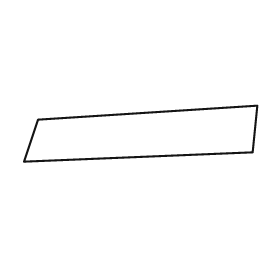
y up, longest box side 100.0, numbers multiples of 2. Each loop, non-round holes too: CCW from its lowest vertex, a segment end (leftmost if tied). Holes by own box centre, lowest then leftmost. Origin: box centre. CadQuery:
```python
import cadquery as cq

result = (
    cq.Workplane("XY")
    .moveTo(-50.0, -12.0)
    .lineTo(48.0, -8.0)
    .lineTo(50.0, 12.0)
    .lineTo(-44.0, 6.0)
    .close()
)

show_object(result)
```